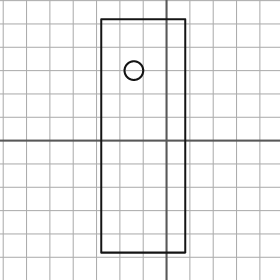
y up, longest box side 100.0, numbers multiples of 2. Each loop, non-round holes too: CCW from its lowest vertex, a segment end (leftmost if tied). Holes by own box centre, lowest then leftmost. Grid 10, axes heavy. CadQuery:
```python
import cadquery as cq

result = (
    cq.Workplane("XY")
    .moveTo(-28.0, -48.0)
    .lineTo(8.0, -48.0)
    .lineTo(8.0, 52.0)
    .lineTo(-28.0, 52.0)
    .close()
    .moveTo(-14.0, 30.0)
    .circle(4.0)
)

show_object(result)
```